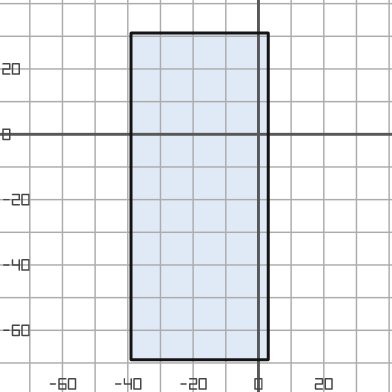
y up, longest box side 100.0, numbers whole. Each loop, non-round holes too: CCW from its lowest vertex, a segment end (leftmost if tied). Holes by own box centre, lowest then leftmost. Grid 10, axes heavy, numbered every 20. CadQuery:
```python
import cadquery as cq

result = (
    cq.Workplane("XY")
    .moveTo(-39.0, -69.0)
    .lineTo(3.0, -69.0)
    .lineTo(3.0, 31.0)
    .lineTo(-39.0, 31.0)
    .close()
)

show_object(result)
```